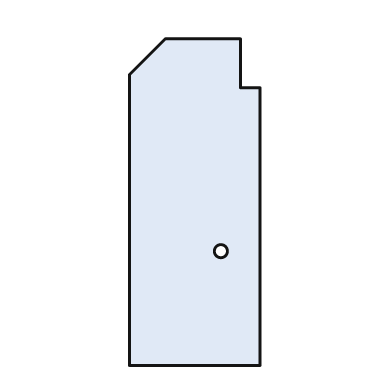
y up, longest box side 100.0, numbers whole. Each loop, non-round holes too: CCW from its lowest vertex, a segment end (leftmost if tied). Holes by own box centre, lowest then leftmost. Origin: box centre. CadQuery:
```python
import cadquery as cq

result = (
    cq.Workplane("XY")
    .moveTo(-20.0, -50.0)
    .lineTo(20.0, -50.0)
    .lineTo(20.0, 35.0)
    .lineTo(14.0, 35.0)
    .lineTo(14.0, 50.0)
    .lineTo(-9.0, 50.0)
    .lineTo(-20.0, 39.0)
    .close()
    .moveTo(8.0, -15.0)
    .circle(2.0)
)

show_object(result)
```